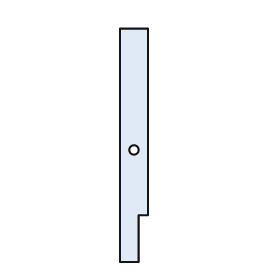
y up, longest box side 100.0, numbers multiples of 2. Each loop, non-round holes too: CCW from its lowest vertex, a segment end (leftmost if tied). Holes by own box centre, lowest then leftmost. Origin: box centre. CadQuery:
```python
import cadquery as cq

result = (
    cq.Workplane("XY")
    .moveTo(-6.0, -50.0)
    .lineTo(2.0, -50.0)
    .lineTo(2.0, -30.0)
    .lineTo(6.0, -30.0)
    .lineTo(6.0, 50.0)
    .lineTo(-6.0, 50.0)
    .close()
    .moveTo(0.0, -2.0)
    .circle(2.0)
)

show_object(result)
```